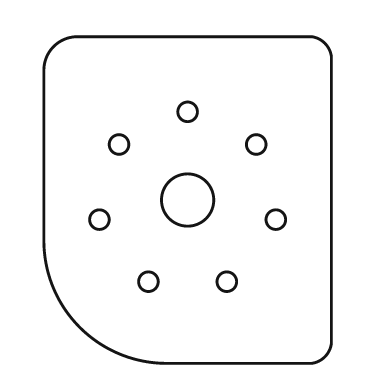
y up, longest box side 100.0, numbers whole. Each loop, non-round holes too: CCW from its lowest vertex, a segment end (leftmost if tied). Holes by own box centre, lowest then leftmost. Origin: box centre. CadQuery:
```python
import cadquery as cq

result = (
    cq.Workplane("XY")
    .moveTo(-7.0, -50.0)
    .lineTo(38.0, -50.0)
    .threePointArc((42.0, -48.0), (44.0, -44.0))
    .lineTo(44.0, 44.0)
    .threePointArc((42.0, 48.0), (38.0, 50.0))
    .lineTo(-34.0, 50.0)
    .threePointArc((-41.0, 47.0), (-44.0, 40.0))
    .lineTo(-44.0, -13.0)
    .threePointArc((-33.0, -39.0), (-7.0, -50.0))
    .close()
    .moveTo(-12.0, -25.0)
    .circle(3.0)
    .moveTo(12.0, -25.0)
    .circle(3.0)
    .moveTo(-27.0, -6.0)
    .circle(3.0)
    .moveTo(27.0, -6.0)
    .circle(3.0)
    .moveTo(0.0, 0.0)
    .circle(8.0)
    .moveTo(-21.0, 17.0)
    .circle(3.0)
    .moveTo(21.0, 17.0)
    .circle(3.0)
    .moveTo(0.0, 27.0)
    .circle(3.0)
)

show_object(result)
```